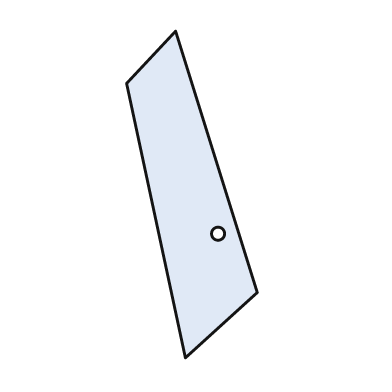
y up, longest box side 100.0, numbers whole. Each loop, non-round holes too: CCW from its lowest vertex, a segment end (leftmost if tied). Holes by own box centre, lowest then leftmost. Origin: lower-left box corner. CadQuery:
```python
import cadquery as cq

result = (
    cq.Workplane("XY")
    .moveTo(18.0, 0.0)
    .lineTo(40.0, 20.0)
    .lineTo(15.0, 100.0)
    .lineTo(0.0, 84.0)
    .close()
    .moveTo(28.0, 38.0)
    .circle(2.0)
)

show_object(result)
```